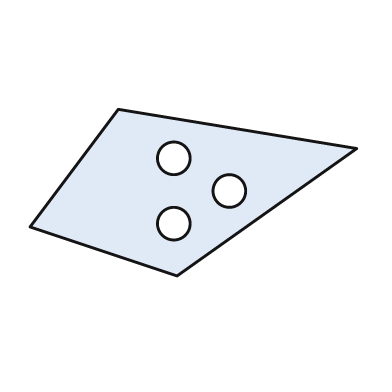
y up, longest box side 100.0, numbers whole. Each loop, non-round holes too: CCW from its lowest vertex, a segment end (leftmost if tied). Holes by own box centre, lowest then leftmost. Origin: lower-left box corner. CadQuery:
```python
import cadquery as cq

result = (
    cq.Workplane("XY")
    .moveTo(45.0, 0.0)
    .lineTo(100.0, 39.0)
    .lineTo(27.0, 51.0)
    .lineTo(0.0, 15.0)
    .close()
    .moveTo(44.0, 16.0)
    .circle(5.0)
    .moveTo(61.0, 26.0)
    .circle(5.0)
    .moveTo(44.0, 36.0)
    .circle(5.0)
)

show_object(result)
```